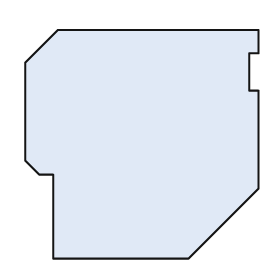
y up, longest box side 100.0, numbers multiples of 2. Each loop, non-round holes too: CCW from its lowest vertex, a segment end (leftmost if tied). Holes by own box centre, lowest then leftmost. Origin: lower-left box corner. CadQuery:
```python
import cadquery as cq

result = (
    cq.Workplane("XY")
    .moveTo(12.0, 0.0)
    .lineTo(70.0, 0.0)
    .lineTo(100.0, 30.0)
    .lineTo(100.0, 72.0)
    .lineTo(96.0, 72.0)
    .lineTo(96.0, 88.0)
    .lineTo(100.0, 88.0)
    .lineTo(100.0, 98.0)
    .lineTo(14.0, 98.0)
    .lineTo(0.0, 84.0)
    .lineTo(0.0, 42.0)
    .lineTo(6.0, 36.0)
    .lineTo(12.0, 36.0)
    .close()
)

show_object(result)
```